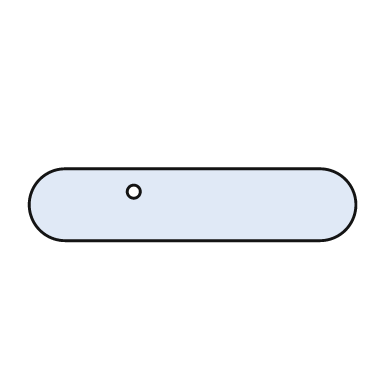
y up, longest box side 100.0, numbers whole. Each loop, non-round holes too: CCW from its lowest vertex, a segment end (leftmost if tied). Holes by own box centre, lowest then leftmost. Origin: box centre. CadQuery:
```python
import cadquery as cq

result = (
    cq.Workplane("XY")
    .moveTo(-39.0, -11.0)
    .lineTo(39.0, -11.0)
    .threePointArc((50.0, 0.0), (39.0, 11.0))
    .lineTo(-39.0, 11.0)
    .threePointArc((-50.0, 0.0), (-39.0, -11.0))
    .close()
    .moveTo(-18.0, 4.0)
    .circle(2.0)
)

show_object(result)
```